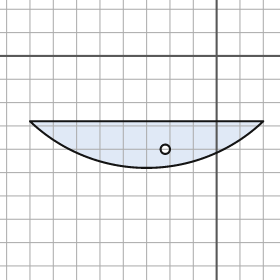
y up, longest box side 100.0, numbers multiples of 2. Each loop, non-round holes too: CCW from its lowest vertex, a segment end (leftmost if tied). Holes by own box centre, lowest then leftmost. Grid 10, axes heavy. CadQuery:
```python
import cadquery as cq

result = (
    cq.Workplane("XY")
    .moveTo(-80.0, -28.0)
    .threePointArc((-30.0, -48.0), (20.0, -28.0))
    .close()
    .moveTo(-22.0, -40.0)
    .circle(2.0)
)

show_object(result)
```